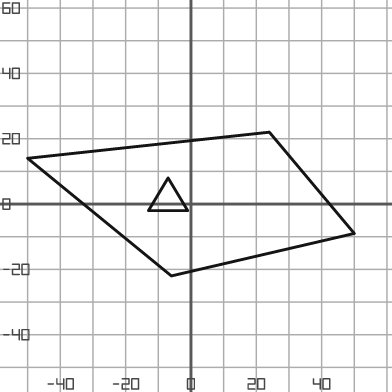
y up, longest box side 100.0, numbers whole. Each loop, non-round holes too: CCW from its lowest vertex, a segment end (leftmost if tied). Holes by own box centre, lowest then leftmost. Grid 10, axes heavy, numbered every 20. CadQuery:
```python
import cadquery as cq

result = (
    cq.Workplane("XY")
    .moveTo(-6.0, -22.0)
    .lineTo(50.0, -9.0)
    .lineTo(24.0, 22.0)
    .lineTo(-50.0, 14.0)
    .close()
    .moveTo(-13.0, -2.0)
    .lineTo(-1.0, -2.0)
    .lineTo(-7.0, 8.0)
    .close()
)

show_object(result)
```